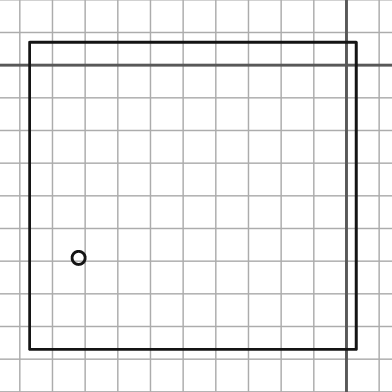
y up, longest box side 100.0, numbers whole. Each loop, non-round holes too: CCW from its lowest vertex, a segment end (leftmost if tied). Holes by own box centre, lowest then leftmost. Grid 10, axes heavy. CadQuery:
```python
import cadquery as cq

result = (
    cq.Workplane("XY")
    .moveTo(-97.0, -87.0)
    .lineTo(3.0, -87.0)
    .lineTo(3.0, 7.0)
    .lineTo(-97.0, 7.0)
    .close()
    .moveTo(-82.0, -59.0)
    .circle(2.0)
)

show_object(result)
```